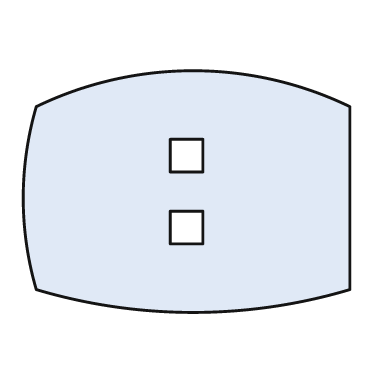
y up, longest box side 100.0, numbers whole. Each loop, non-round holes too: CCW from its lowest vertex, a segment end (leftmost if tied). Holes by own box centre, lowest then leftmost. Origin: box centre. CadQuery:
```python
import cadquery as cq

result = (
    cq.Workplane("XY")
    .moveTo(-46.0, -30.0)
    .threePointArc((2.0, -37.0), (50.0, -30.0))
    .lineTo(50.0, 26.0)
    .threePointArc((2.0, 37.0), (-46.0, 26.0))
    .threePointArc((-50.0, -2.0), (-46.0, -30.0))
    .close()
    .moveTo(-5.0, -16.0)
    .lineTo(5.0, -16.0)
    .lineTo(5.0, -6.0)
    .lineTo(-5.0, -6.0)
    .close()
    .moveTo(-5.0, 6.0)
    .lineTo(5.0, 6.0)
    .lineTo(5.0, 16.0)
    .lineTo(-5.0, 16.0)
    .close()
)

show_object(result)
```